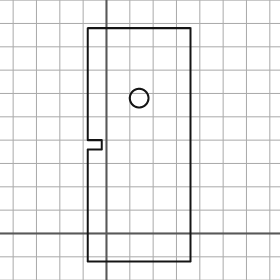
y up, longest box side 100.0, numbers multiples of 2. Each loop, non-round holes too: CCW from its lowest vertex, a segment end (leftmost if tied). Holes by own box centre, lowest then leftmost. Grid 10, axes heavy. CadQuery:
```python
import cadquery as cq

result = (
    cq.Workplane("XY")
    .moveTo(-8.0, -12.0)
    .lineTo(36.0, -12.0)
    .lineTo(36.0, 88.0)
    .lineTo(-8.0, 88.0)
    .lineTo(-8.0, 40.0)
    .lineTo(-2.0, 40.0)
    .lineTo(-2.0, 36.0)
    .lineTo(-8.0, 36.0)
    .close()
    .moveTo(14.0, 58.0)
    .circle(4.0)
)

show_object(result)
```